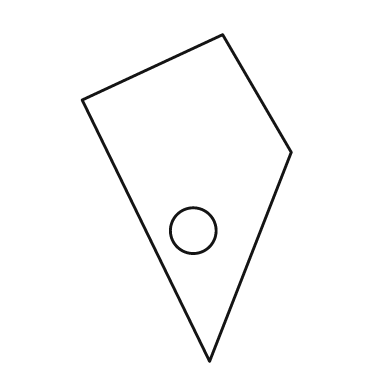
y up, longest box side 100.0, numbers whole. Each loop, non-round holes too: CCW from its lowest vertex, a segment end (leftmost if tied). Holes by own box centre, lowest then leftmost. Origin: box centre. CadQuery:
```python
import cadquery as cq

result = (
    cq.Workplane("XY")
    .moveTo(7.0, -50.0)
    .lineTo(32.0, 14.0)
    .lineTo(11.0, 50.0)
    .lineTo(-32.0, 30.0)
    .close()
    .moveTo(2.0, -10.0)
    .circle(7.0)
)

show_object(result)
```